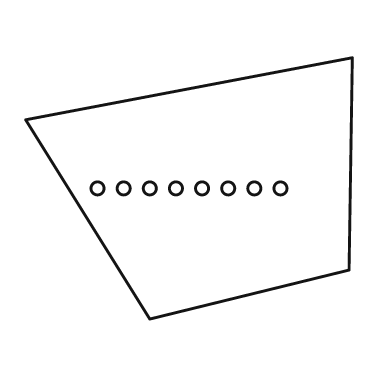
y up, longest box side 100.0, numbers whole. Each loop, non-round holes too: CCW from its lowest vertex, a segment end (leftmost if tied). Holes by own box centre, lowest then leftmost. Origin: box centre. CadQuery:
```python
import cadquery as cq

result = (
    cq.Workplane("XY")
    .moveTo(-12.0, -40.0)
    .lineTo(49.0, -25.0)
    .lineTo(50.0, 40.0)
    .lineTo(-50.0, 21.0)
    .close()
    .moveTo(-28.0, 0.0)
    .circle(2.0)
    .moveTo(-20.0, 0.0)
    .circle(2.0)
    .moveTo(-12.0, 0.0)
    .circle(2.0)
    .moveTo(-4.0, 0.0)
    .circle(2.0)
    .moveTo(4.0, 0.0)
    .circle(2.0)
    .moveTo(12.0, 0.0)
    .circle(2.0)
    .moveTo(20.0, 0.0)
    .circle(2.0)
    .moveTo(28.0, 0.0)
    .circle(2.0)
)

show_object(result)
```